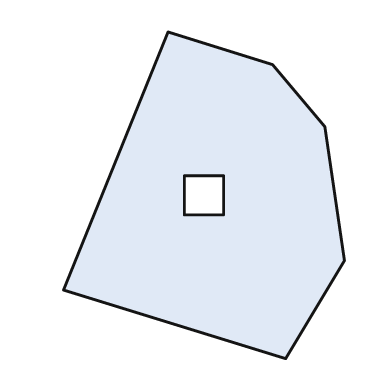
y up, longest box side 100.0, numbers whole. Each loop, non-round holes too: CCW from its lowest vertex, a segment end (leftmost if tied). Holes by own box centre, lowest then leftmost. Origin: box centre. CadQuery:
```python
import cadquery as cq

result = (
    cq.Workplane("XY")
    .moveTo(25.0, -50.0)
    .lineTo(43.0, -20.0)
    .lineTo(37.0, 21.0)
    .lineTo(21.0, 40.0)
    .lineTo(-11.0, 50.0)
    .lineTo(-43.0, -29.0)
    .close()
    .moveTo(-6.0, -6.0)
    .lineTo(6.0, -6.0)
    .lineTo(6.0, 6.0)
    .lineTo(-6.0, 6.0)
    .close()
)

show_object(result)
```